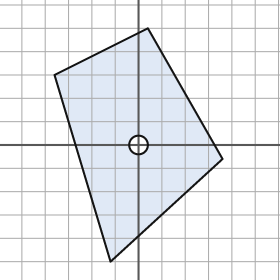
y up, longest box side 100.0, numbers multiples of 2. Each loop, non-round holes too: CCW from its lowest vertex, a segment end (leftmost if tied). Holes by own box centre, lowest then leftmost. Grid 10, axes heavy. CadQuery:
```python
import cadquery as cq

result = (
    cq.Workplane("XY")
    .moveTo(-12.0, -50.0)
    .lineTo(36.0, -6.0)
    .lineTo(4.0, 50.0)
    .lineTo(-36.0, 30.0)
    .close()
    .moveTo(0.0, 0.0)
    .circle(4.0)
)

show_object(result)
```